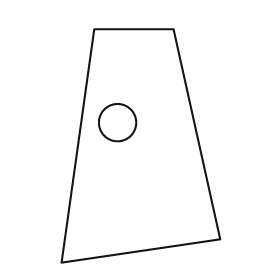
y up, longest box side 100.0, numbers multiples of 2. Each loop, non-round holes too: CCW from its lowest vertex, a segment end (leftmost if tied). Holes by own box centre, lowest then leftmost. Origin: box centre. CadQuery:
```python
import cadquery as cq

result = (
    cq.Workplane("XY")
    .moveTo(-34.0, -50.0)
    .lineTo(34.0, -40.0)
    .lineTo(14.0, 50.0)
    .lineTo(-20.0, 50.0)
    .close()
    .moveTo(-10.0, 10.0)
    .circle(8.0)
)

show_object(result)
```